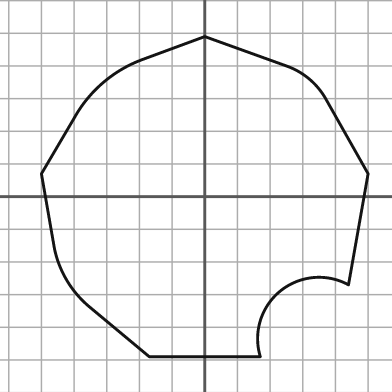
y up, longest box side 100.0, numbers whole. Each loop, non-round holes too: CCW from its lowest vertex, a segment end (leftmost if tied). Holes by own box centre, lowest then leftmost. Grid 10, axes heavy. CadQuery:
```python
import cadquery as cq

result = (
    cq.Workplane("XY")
    .moveTo(-17.0, -49.0)
    .lineTo(17.0, -49.0)
    .threePointArc((23.0, -29.0), (44.0, -27.0))
    .lineTo(50.0, 7.0)
    .lineTo(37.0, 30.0)
    .threePointArc((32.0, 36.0), (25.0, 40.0))
    .lineTo(0.0, 49.0)
    .lineTo(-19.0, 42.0)
    .threePointArc((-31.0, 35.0), (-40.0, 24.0))
    .lineTo(-50.0, 7.0)
    .lineTo(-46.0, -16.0)
    .threePointArc((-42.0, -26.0), (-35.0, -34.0))
    .close()
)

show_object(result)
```